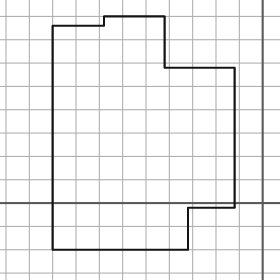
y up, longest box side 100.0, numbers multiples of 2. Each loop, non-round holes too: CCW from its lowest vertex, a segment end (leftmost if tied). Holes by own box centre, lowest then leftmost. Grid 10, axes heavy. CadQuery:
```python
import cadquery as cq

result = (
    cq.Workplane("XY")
    .moveTo(-90.0, -20.0)
    .lineTo(-32.0, -20.0)
    .lineTo(-32.0, -2.0)
    .lineTo(-12.0, -2.0)
    .lineTo(-12.0, 58.0)
    .lineTo(-42.0, 58.0)
    .lineTo(-42.0, 80.0)
    .lineTo(-68.0, 80.0)
    .lineTo(-68.0, 76.0)
    .lineTo(-90.0, 76.0)
    .close()
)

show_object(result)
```